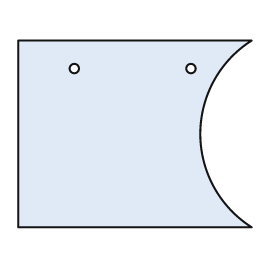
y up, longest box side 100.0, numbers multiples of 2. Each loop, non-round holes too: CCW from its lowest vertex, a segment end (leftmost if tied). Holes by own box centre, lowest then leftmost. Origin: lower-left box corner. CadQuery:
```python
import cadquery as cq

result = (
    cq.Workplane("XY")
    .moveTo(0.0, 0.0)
    .lineTo(100.0, 0.0)
    .threePointArc((78.0, 40.0), (100.0, 80.0))
    .lineTo(0.0, 80.0)
    .close()
    .moveTo(24.0, 68.0)
    .circle(2.0)
    .moveTo(74.0, 68.0)
    .circle(2.0)
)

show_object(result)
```